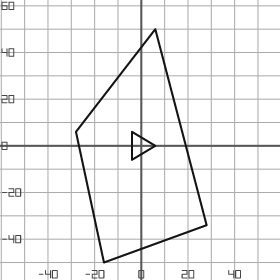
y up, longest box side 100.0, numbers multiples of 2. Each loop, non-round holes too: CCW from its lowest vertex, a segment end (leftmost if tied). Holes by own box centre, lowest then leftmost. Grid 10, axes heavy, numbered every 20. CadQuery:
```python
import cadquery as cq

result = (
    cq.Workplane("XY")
    .moveTo(-16.0, -50.0)
    .lineTo(28.0, -34.0)
    .lineTo(6.0, 50.0)
    .lineTo(-28.0, 6.0)
    .close()
    .moveTo(-4.0, -6.0)
    .lineTo(6.0, 0.0)
    .lineTo(-4.0, 6.0)
    .close()
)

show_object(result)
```